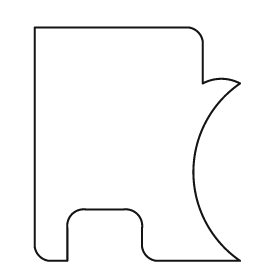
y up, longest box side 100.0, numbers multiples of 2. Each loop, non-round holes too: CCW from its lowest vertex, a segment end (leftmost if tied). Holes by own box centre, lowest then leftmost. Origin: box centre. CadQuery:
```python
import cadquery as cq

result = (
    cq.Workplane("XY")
    .moveTo(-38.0, -50.0)
    .lineTo(-30.0, -50.0)
    .lineTo(-30.0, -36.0)
    .threePointArc((-28.0, -30.0), (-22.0, -28.0))
    .lineTo(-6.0, -28.0)
    .threePointArc((0.0, -30.0), (2.0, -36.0))
    .lineTo(2.0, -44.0)
    .threePointArc((4.0, -48.0), (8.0, -50.0))
    .lineTo(44.0, -50.0)
    .threePointArc((24.0, -12.0), (44.0, 26.0))
    .threePointArc((36.0, 28.0), (28.0, 26.0))
    .lineTo(28.0, 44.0)
    .threePointArc((26.0, 48.0), (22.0, 50.0))
    .lineTo(-44.0, 50.0)
    .lineTo(-44.0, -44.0)
    .threePointArc((-42.0, -48.0), (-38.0, -50.0))
    .close()
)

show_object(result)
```